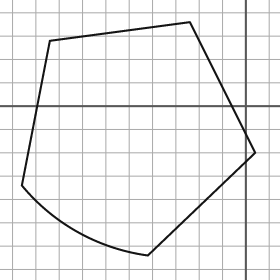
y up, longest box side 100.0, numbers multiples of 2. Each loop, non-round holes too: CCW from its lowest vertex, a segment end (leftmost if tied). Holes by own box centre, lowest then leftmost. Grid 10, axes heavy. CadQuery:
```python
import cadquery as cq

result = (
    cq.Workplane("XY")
    .moveTo(-42.0, -64.0)
    .lineTo(4.0, -20.0)
    .lineTo(-24.0, 36.0)
    .lineTo(-84.0, 28.0)
    .lineTo(-96.0, -34.0)
    .threePointArc((-72.0, -54.0), (-42.0, -64.0))
    .close()
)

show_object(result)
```